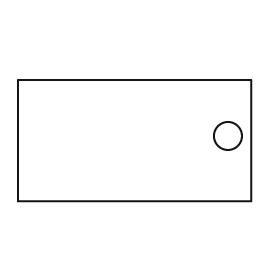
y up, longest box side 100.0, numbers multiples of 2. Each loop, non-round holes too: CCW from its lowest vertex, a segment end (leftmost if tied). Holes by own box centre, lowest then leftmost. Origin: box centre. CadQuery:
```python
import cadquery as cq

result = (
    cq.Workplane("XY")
    .moveTo(-50.0, -26.0)
    .lineTo(50.0, -26.0)
    .lineTo(50.0, 26.0)
    .lineTo(-50.0, 26.0)
    .close()
    .moveTo(40.0, 2.0)
    .circle(6.0)
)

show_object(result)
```